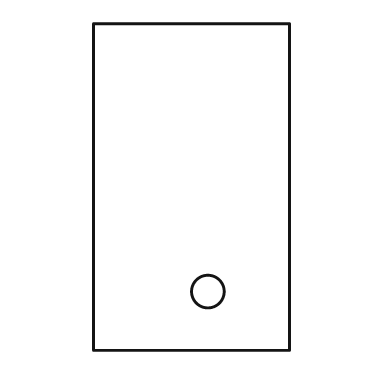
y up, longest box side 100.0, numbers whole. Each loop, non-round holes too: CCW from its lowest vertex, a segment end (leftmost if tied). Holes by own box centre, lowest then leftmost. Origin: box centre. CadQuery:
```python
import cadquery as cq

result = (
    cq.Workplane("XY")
    .moveTo(-30.0, -50.0)
    .lineTo(30.0, -50.0)
    .lineTo(30.0, 50.0)
    .lineTo(-30.0, 50.0)
    .close()
    .moveTo(5.0, -32.0)
    .circle(5.0)
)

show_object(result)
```